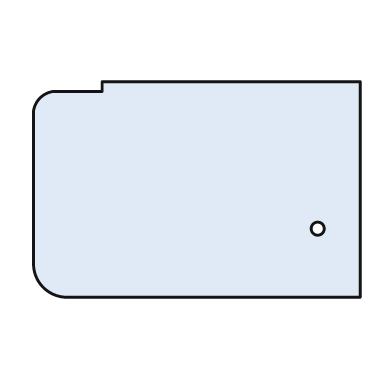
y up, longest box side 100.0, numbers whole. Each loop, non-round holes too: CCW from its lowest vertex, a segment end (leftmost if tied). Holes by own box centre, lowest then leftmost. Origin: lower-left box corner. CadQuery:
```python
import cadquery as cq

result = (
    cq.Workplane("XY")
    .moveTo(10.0, 0.0)
    .lineTo(100.0, 0.0)
    .lineTo(100.0, 66.0)
    .lineTo(21.0, 66.0)
    .lineTo(21.0, 63.0)
    .lineTo(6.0, 63.0)
    .threePointArc((2.0, 61.0), (0.0, 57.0))
    .lineTo(0.0, 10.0)
    .threePointArc((3.0, 3.0), (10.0, 0.0))
    .close()
    .moveTo(87.0, 21.0)
    .circle(2.0)
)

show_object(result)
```